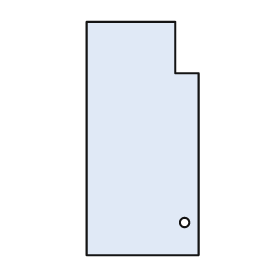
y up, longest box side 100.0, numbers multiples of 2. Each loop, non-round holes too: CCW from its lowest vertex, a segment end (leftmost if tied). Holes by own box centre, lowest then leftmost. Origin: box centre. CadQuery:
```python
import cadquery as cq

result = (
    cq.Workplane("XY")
    .moveTo(-24.0, -50.0)
    .lineTo(24.0, -50.0)
    .lineTo(24.0, 28.0)
    .lineTo(14.0, 28.0)
    .lineTo(14.0, 50.0)
    .lineTo(-24.0, 50.0)
    .close()
    .moveTo(18.0, -36.0)
    .circle(2.0)
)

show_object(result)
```